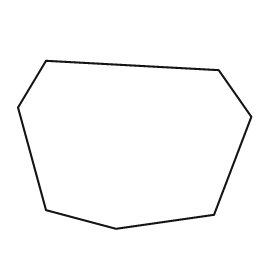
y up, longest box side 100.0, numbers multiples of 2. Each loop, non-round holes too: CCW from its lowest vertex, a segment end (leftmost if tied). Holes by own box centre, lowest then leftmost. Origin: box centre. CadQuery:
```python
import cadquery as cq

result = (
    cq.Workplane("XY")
    .moveTo(-8.0, -36.0)
    .lineTo(34.0, -30.0)
    .lineTo(50.0, 12.0)
    .lineTo(36.0, 32.0)
    .lineTo(-38.0, 36.0)
    .lineTo(-50.0, 16.0)
    .lineTo(-38.0, -28.0)
    .close()
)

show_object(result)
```